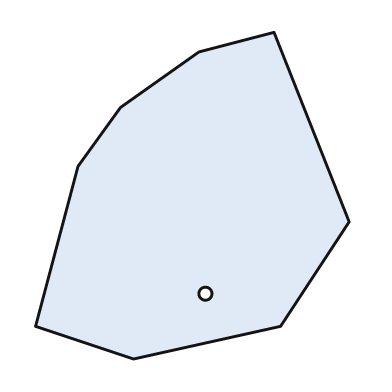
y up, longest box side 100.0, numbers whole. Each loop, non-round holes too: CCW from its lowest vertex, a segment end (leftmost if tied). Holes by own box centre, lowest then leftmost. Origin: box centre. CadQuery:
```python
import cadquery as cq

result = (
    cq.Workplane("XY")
    .moveTo(-18.0, -50.0)
    .lineTo(27.0, -40.0)
    .lineTo(48.0, -8.0)
    .lineTo(25.0, 50.0)
    .lineTo(2.0, 44.0)
    .lineTo(-22.0, 27.0)
    .lineTo(-35.0, 9.0)
    .lineTo(-48.0, -40.0)
    .close()
    .moveTo(4.0, -30.0)
    .circle(2.0)
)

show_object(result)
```